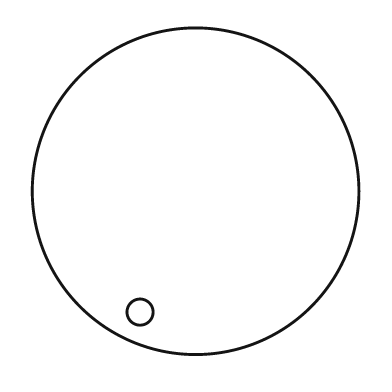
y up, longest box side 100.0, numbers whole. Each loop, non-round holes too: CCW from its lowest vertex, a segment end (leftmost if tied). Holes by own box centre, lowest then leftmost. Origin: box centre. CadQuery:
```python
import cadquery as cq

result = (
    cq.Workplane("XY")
    .moveTo(0.0, 0.0)
    .circle(50.0)
    .moveTo(-17.0, -37.0)
    .circle(4.0)
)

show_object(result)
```